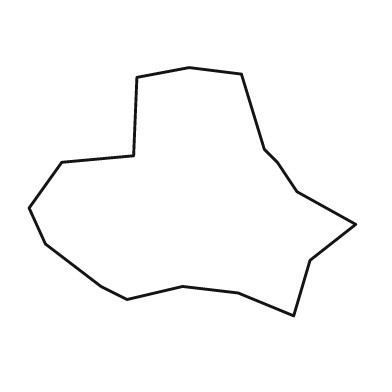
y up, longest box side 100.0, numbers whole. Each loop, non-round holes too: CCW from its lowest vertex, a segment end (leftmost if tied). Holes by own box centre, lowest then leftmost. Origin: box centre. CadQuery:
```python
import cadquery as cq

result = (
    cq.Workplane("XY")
    .moveTo(31.0, -38.0)
    .lineTo(36.0, -21.0)
    .lineTo(50.0, -10.0)
    .lineTo(32.0, 0.0)
    .lineTo(26.0, 9.0)
    .lineTo(22.0, 13.0)
    .lineTo(15.0, 36.0)
    .lineTo(-1.0, 38.0)
    .lineTo(-17.0, 35.0)
    .lineTo(-18.0, 11.0)
    .lineTo(-40.0, 9.0)
    .lineTo(-50.0, -5.0)
    .lineTo(-45.0, -16.0)
    .lineTo(-28.0, -29.0)
    .lineTo(-20.0, -33.0)
    .lineTo(-3.0, -29.0)
    .lineTo(14.0, -31.0)
    .close()
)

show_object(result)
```